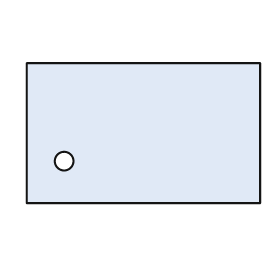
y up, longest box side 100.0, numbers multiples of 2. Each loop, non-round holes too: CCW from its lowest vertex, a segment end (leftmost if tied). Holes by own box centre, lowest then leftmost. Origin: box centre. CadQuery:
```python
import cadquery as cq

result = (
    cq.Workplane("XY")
    .moveTo(-50.0, -30.0)
    .lineTo(50.0, -30.0)
    .lineTo(50.0, 30.0)
    .lineTo(-50.0, 30.0)
    .close()
    .moveTo(-34.0, -12.0)
    .circle(4.0)
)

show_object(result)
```